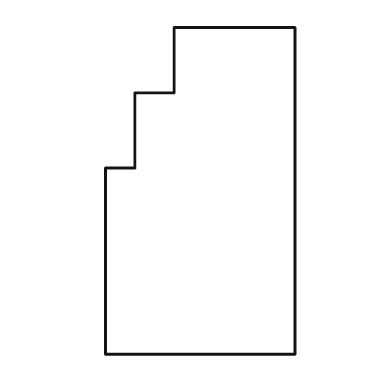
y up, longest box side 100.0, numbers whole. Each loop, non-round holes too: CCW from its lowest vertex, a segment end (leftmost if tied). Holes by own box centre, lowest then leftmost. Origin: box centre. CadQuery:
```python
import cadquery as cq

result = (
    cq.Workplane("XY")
    .moveTo(-29.0, -50.0)
    .lineTo(29.0, -50.0)
    .lineTo(29.0, 50.0)
    .lineTo(-8.0, 50.0)
    .lineTo(-8.0, 30.0)
    .lineTo(-20.0, 30.0)
    .lineTo(-20.0, 7.0)
    .lineTo(-29.0, 7.0)
    .close()
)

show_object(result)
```